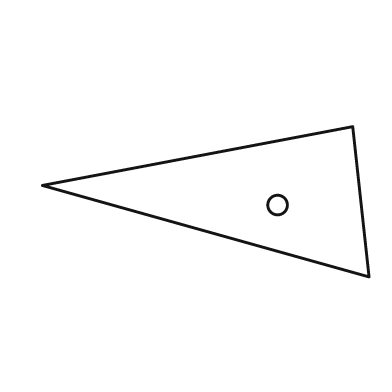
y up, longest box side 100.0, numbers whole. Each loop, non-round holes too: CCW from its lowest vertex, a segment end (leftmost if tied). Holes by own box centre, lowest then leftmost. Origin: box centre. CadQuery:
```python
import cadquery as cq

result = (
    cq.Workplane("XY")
    .moveTo(50.0, -23.0)
    .lineTo(45.0, 23.0)
    .lineTo(-50.0, 5.0)
    .close()
    .moveTo(22.0, -1.0)
    .circle(3.0)
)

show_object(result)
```